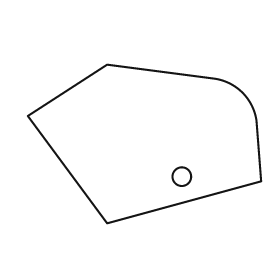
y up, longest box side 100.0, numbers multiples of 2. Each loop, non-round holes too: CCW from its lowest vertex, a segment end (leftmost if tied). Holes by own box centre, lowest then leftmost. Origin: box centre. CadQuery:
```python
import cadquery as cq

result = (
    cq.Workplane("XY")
    .moveTo(-16.0, -34.0)
    .lineTo(50.0, -16.0)
    .lineTo(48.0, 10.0)
    .threePointArc((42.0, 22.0), (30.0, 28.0))
    .lineTo(-16.0, 34.0)
    .lineTo(-50.0, 12.0)
    .close()
    .moveTo(16.0, -14.0)
    .circle(4.0)
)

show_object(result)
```